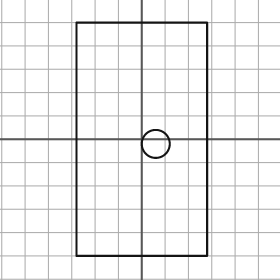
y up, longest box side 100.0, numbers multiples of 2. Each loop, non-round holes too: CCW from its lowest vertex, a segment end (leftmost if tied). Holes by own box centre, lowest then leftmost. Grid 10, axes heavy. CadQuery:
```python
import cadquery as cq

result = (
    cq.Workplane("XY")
    .moveTo(-28.0, -50.0)
    .lineTo(28.0, -50.0)
    .lineTo(28.0, 50.0)
    .lineTo(-28.0, 50.0)
    .close()
    .moveTo(6.0, -2.0)
    .circle(6.0)
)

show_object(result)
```